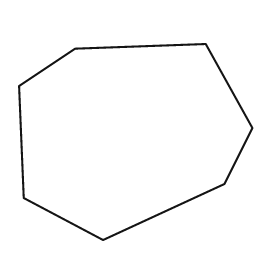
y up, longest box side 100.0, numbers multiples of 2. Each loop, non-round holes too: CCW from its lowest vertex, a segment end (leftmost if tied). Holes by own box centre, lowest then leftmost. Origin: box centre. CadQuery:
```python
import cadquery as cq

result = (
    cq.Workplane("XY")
    .moveTo(-14.0, -42.0)
    .lineTo(38.0, -18.0)
    .lineTo(50.0, 6.0)
    .lineTo(30.0, 42.0)
    .lineTo(-26.0, 40.0)
    .lineTo(-50.0, 24.0)
    .lineTo(-48.0, -24.0)
    .close()
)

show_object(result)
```